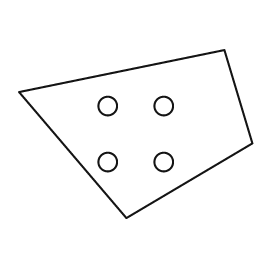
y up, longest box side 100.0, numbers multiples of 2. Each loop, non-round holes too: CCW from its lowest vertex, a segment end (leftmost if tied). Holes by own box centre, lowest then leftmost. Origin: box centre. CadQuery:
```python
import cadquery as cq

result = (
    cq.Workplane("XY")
    .moveTo(-4.0, -36.0)
    .lineTo(50.0, -4.0)
    .lineTo(38.0, 36.0)
    .lineTo(-50.0, 18.0)
    .close()
    .moveTo(-12.0, -12.0)
    .circle(4.0)
    .moveTo(12.0, -12.0)
    .circle(4.0)
    .moveTo(-12.0, 12.0)
    .circle(4.0)
    .moveTo(12.0, 12.0)
    .circle(4.0)
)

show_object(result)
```